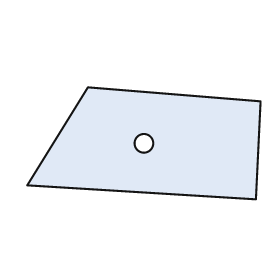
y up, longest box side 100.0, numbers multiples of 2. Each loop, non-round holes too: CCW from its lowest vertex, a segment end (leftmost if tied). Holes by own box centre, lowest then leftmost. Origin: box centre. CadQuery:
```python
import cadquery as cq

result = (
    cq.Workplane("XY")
    .moveTo(48.0, -24.0)
    .lineTo(50.0, 18.0)
    .lineTo(-24.0, 24.0)
    .lineTo(-50.0, -18.0)
    .close()
    .moveTo(0.0, 0.0)
    .circle(4.0)
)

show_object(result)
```